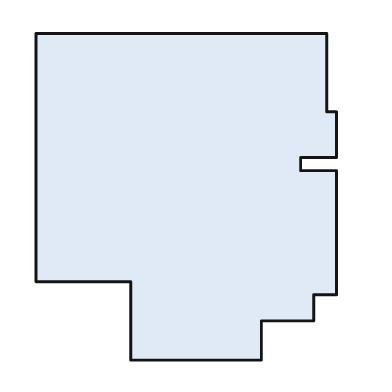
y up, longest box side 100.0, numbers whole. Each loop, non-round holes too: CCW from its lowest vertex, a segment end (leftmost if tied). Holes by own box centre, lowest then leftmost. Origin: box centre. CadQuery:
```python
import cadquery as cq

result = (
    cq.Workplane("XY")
    .moveTo(-17.0, -50.0)
    .lineTo(23.0, -50.0)
    .lineTo(23.0, -38.0)
    .lineTo(39.0, -38.0)
    .lineTo(39.0, -30.0)
    .lineTo(46.0, -30.0)
    .lineTo(46.0, 8.0)
    .lineTo(35.0, 8.0)
    .lineTo(35.0, 12.0)
    .lineTo(46.0, 12.0)
    .lineTo(46.0, 26.0)
    .lineTo(43.0, 26.0)
    .lineTo(43.0, 50.0)
    .lineTo(-46.0, 50.0)
    .lineTo(-46.0, -26.0)
    .lineTo(-17.0, -26.0)
    .close()
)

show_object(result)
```